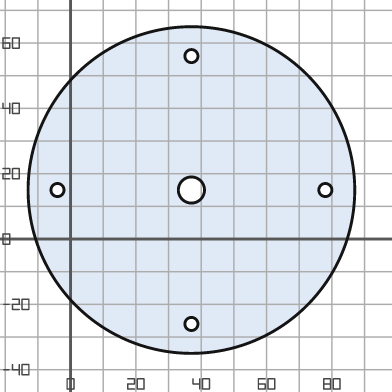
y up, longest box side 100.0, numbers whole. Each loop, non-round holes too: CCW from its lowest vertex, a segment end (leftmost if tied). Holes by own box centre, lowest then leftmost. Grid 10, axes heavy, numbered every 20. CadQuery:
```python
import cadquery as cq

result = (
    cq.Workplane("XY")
    .moveTo(37.0, 15.0)
    .circle(50.0)
    .moveTo(37.0, -26.0)
    .circle(2.0)
    .moveTo(-4.0, 15.0)
    .circle(2.0)
    .moveTo(37.0, 15.0)
    .circle(4.0)
    .moveTo(78.0, 15.0)
    .circle(2.0)
    .moveTo(37.0, 56.0)
    .circle(2.0)
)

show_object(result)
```